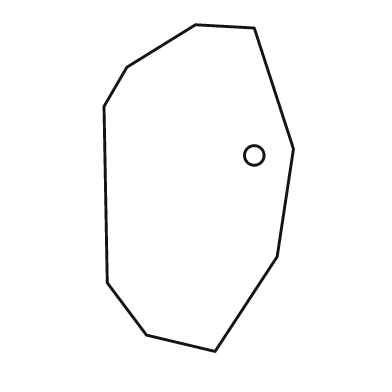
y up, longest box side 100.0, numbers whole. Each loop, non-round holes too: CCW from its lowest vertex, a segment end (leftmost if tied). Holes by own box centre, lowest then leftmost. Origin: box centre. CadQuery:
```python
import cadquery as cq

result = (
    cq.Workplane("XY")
    .moveTo(5.0, -50.0)
    .lineTo(24.0, -21.0)
    .lineTo(29.0, 12.0)
    .lineTo(17.0, 49.0)
    .lineTo(-1.0, 50.0)
    .lineTo(-22.0, 37.0)
    .lineTo(-29.0, 25.0)
    .lineTo(-28.0, -29.0)
    .lineTo(-16.0, -45.0)
    .close()
    .moveTo(17.0, 10.0)
    .circle(3.0)
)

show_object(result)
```